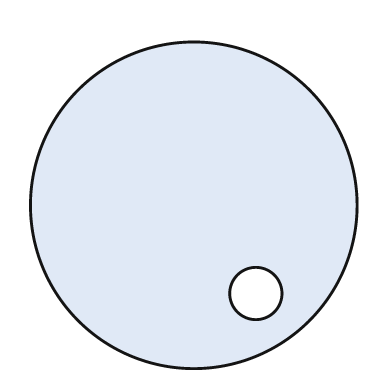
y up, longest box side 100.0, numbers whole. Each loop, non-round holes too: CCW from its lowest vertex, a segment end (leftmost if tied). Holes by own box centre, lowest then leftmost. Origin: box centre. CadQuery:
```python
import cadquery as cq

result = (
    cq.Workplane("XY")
    .moveTo(0.0, 0.0)
    .circle(50.0)
    .moveTo(19.0, -27.0)
    .circle(8.0)
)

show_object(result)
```